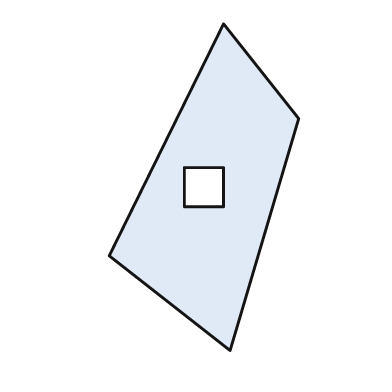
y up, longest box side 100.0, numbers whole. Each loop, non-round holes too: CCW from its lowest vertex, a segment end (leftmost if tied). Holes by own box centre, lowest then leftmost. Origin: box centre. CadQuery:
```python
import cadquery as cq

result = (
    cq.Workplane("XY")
    .moveTo(8.0, -50.0)
    .lineTo(29.0, 21.0)
    .lineTo(6.0, 50.0)
    .lineTo(-29.0, -21.0)
    .close()
    .moveTo(-6.0, -6.0)
    .lineTo(6.0, -6.0)
    .lineTo(6.0, 6.0)
    .lineTo(-6.0, 6.0)
    .close()
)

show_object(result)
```